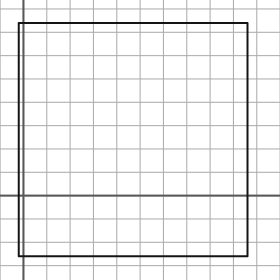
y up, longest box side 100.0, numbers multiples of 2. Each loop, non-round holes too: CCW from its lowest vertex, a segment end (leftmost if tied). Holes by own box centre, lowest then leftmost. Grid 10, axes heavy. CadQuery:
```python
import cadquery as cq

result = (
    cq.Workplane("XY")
    .moveTo(-2.0, -26.0)
    .lineTo(96.0, -26.0)
    .lineTo(96.0, 74.0)
    .lineTo(-2.0, 74.0)
    .close()
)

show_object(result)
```